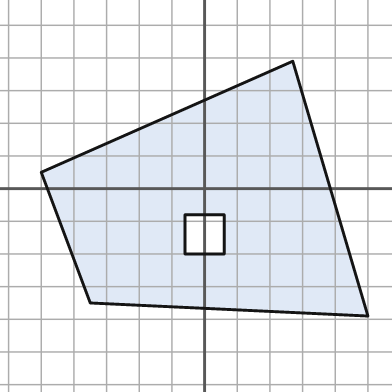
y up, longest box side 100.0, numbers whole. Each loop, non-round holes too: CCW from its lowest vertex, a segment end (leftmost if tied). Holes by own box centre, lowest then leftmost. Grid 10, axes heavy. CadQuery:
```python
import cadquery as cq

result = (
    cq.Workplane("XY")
    .moveTo(50.0, -39.0)
    .lineTo(27.0, 39.0)
    .lineTo(-50.0, 5.0)
    .lineTo(-35.0, -35.0)
    .close()
    .moveTo(-6.0, -20.0)
    .lineTo(6.0, -20.0)
    .lineTo(6.0, -8.0)
    .lineTo(-6.0, -8.0)
    .close()
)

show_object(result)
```